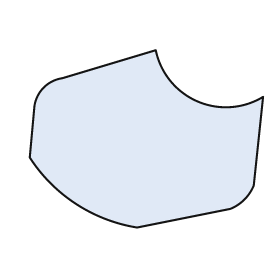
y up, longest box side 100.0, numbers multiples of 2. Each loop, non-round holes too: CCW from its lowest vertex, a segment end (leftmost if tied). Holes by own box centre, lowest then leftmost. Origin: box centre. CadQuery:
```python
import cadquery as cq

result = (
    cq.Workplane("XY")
    .moveTo(-4.0, -38.0)
    .lineTo(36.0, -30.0)
    .threePointArc((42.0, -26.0), (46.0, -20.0))
    .lineTo(50.0, 18.0)
    .threePointArc((22.0, 16.0), (4.0, 38.0))
    .lineTo(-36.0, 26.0)
    .threePointArc((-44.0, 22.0), (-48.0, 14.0))
    .lineTo(-50.0, -8.0)
    .threePointArc((-30.0, -28.0), (-4.0, -38.0))
    .close()
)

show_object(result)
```